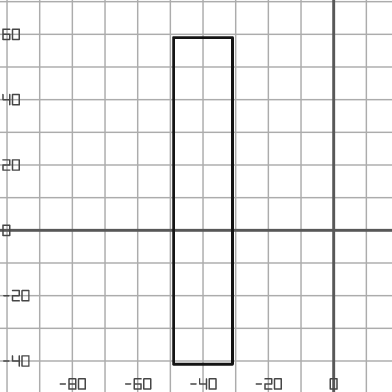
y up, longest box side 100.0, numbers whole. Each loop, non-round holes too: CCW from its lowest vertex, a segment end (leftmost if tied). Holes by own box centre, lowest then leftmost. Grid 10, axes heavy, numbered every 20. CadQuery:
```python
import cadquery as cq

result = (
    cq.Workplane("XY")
    .moveTo(-49.0, -41.0)
    .lineTo(-31.0, -41.0)
    .lineTo(-31.0, 59.0)
    .lineTo(-49.0, 59.0)
    .close()
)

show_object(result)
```